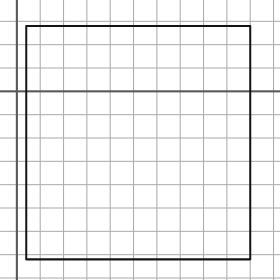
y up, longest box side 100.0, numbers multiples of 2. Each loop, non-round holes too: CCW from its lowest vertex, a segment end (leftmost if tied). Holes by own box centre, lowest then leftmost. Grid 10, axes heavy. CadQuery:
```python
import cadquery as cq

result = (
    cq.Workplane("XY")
    .moveTo(4.0, -72.0)
    .lineTo(100.0, -72.0)
    .lineTo(100.0, 28.0)
    .lineTo(4.0, 28.0)
    .close()
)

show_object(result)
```